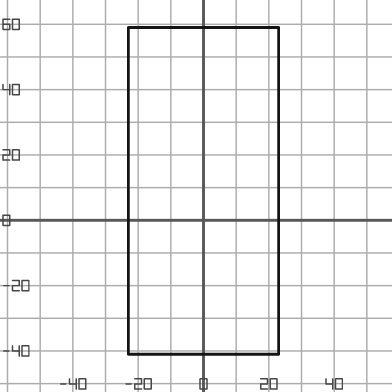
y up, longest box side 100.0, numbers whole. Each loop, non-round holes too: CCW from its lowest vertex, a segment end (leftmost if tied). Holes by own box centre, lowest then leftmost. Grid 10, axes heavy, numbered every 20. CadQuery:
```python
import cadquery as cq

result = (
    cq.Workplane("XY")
    .moveTo(-23.0, -41.0)
    .lineTo(23.0, -41.0)
    .lineTo(23.0, 59.0)
    .lineTo(-23.0, 59.0)
    .close()
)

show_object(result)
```